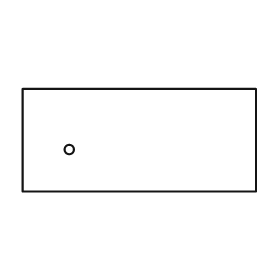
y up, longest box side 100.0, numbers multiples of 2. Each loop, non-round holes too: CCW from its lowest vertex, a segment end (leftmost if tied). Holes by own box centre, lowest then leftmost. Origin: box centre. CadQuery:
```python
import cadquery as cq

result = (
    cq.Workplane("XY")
    .moveTo(-50.0, -22.0)
    .lineTo(50.0, -22.0)
    .lineTo(50.0, 22.0)
    .lineTo(-50.0, 22.0)
    .close()
    .moveTo(-30.0, -4.0)
    .circle(2.0)
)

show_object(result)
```